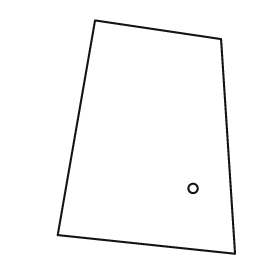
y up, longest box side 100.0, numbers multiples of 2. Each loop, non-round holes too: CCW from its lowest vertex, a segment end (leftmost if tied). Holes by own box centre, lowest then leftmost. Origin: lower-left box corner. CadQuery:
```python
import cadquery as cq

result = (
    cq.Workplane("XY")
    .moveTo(76.0, 0.0)
    .lineTo(70.0, 92.0)
    .lineTo(16.0, 100.0)
    .lineTo(0.0, 8.0)
    .close()
    .moveTo(58.0, 28.0)
    .circle(2.0)
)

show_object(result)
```